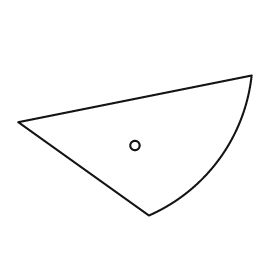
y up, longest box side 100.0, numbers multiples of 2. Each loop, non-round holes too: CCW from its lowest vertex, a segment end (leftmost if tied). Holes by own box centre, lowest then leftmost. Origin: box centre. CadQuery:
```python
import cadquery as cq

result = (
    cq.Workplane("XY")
    .moveTo(6.0, -30.0)
    .threePointArc((36.0, -6.0), (50.0, 30.0))
    .lineTo(-50.0, 10.0)
    .close()
    .moveTo(0.0, 0.0)
    .circle(2.0)
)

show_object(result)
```